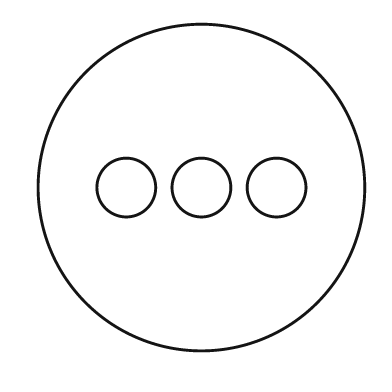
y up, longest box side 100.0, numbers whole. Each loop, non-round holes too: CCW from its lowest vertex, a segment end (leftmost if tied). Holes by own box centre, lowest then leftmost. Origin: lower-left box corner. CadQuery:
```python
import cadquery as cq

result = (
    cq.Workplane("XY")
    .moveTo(50.0, 50.0)
    .circle(50.0)
    .moveTo(27.0, 50.0)
    .circle(9.0)
    .moveTo(50.0, 50.0)
    .circle(9.0)
    .moveTo(73.0, 50.0)
    .circle(9.0)
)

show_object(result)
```